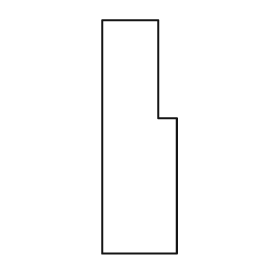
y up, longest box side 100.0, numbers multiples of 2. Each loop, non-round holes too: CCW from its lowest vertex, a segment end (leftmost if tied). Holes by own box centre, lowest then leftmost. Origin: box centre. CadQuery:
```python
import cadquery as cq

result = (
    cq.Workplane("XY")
    .moveTo(-16.0, -50.0)
    .lineTo(16.0, -50.0)
    .lineTo(16.0, 8.0)
    .lineTo(8.0, 8.0)
    .lineTo(8.0, 50.0)
    .lineTo(-16.0, 50.0)
    .close()
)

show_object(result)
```